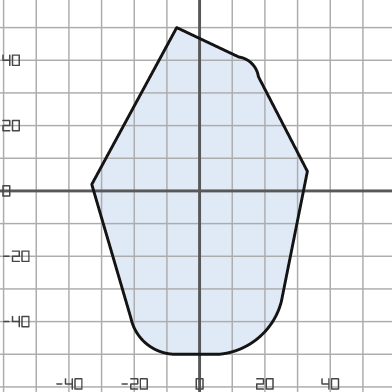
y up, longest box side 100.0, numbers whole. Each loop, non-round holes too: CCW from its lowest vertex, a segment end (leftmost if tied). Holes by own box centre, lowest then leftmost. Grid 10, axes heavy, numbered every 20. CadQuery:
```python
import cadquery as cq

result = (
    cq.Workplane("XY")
    .moveTo(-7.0, -50.0)
    .lineTo(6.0, -50.0)
    .threePointArc((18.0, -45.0), (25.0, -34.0))
    .lineTo(33.0, 6.0)
    .lineTo(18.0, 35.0)
    .threePointArc((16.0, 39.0), (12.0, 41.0))
    .lineTo(-7.0, 50.0)
    .lineTo(-33.0, 2.0)
    .lineTo(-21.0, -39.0)
    .threePointArc((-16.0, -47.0), (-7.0, -50.0))
    .close()
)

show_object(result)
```